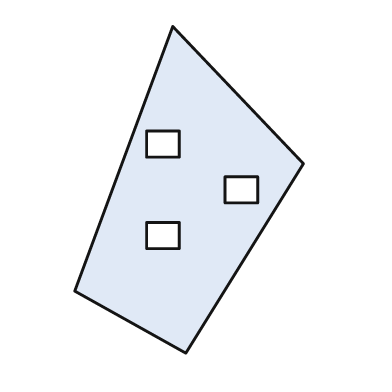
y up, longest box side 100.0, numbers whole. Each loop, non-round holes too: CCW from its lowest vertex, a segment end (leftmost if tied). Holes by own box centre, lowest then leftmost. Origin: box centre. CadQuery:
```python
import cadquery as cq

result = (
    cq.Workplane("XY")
    .moveTo(-1.0, -50.0)
    .lineTo(35.0, 8.0)
    .lineTo(-5.0, 50.0)
    .lineTo(-35.0, -31.0)
    .close()
    .moveTo(-13.0, -18.0)
    .lineTo(-3.0, -18.0)
    .lineTo(-3.0, -10.0)
    .lineTo(-13.0, -10.0)
    .close()
    .moveTo(11.0, -4.0)
    .lineTo(21.0, -4.0)
    .lineTo(21.0, 4.0)
    .lineTo(11.0, 4.0)
    .close()
    .moveTo(-13.0, 10.0)
    .lineTo(-3.0, 10.0)
    .lineTo(-3.0, 18.0)
    .lineTo(-13.0, 18.0)
    .close()
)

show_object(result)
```